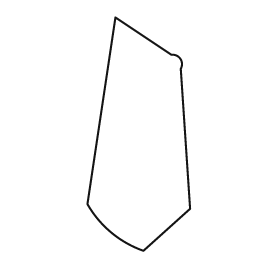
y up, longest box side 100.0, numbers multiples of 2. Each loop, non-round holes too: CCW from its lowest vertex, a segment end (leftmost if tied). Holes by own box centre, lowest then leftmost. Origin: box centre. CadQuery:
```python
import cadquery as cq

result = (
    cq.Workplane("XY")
    .moveTo(2.0, -50.0)
    .lineTo(22.0, -32.0)
    .lineTo(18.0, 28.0)
    .threePointArc((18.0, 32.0), (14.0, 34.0))
    .lineTo(-10.0, 50.0)
    .lineTo(-22.0, -30.0)
    .threePointArc((-12.0, -42.0), (2.0, -50.0))
    .close()
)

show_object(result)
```